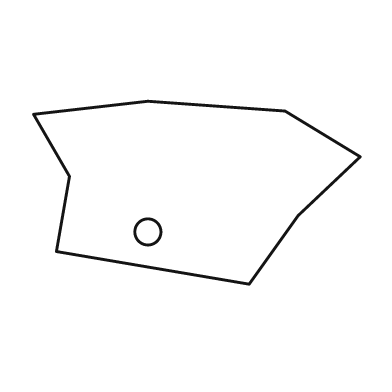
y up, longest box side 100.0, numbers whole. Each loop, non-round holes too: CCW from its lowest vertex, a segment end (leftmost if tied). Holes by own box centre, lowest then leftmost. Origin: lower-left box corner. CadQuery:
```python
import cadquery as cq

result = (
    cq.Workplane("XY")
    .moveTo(66.0, 0.0)
    .lineTo(81.0, 21.0)
    .lineTo(100.0, 39.0)
    .lineTo(77.0, 53.0)
    .lineTo(35.0, 56.0)
    .lineTo(0.0, 52.0)
    .lineTo(11.0, 33.0)
    .lineTo(7.0, 10.0)
    .close()
    .moveTo(35.0, 16.0)
    .circle(4.0)
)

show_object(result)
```